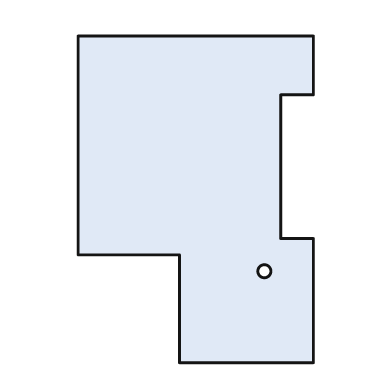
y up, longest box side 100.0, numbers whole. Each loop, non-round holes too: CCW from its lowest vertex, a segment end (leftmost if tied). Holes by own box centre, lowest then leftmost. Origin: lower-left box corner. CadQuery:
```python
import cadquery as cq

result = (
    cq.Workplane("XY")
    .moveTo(31.0, 0.0)
    .lineTo(72.0, 0.0)
    .lineTo(72.0, 38.0)
    .lineTo(62.0, 38.0)
    .lineTo(62.0, 82.0)
    .lineTo(72.0, 82.0)
    .lineTo(72.0, 100.0)
    .lineTo(0.0, 100.0)
    .lineTo(0.0, 33.0)
    .lineTo(31.0, 33.0)
    .close()
    .moveTo(57.0, 28.0)
    .circle(2.0)
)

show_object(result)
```